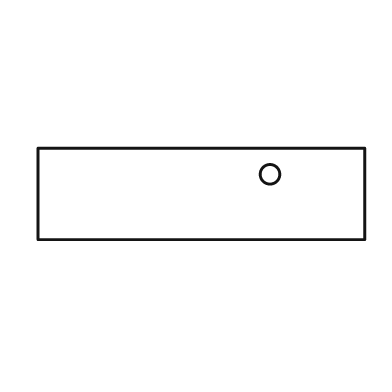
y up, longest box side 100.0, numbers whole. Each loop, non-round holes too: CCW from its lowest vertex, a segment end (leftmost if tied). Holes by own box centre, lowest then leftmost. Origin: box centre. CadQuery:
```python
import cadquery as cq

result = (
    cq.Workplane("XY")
    .moveTo(-50.0, -14.0)
    .lineTo(50.0, -14.0)
    .lineTo(50.0, 14.0)
    .lineTo(-50.0, 14.0)
    .close()
    .moveTo(21.0, 6.0)
    .circle(3.0)
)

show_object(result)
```